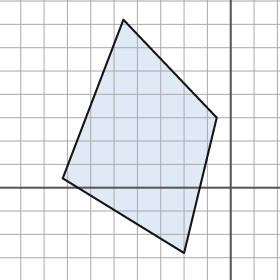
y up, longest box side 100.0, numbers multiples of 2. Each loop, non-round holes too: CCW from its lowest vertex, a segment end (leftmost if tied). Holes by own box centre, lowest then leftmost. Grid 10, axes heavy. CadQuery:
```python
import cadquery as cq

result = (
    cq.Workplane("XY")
    .moveTo(-20.0, -28.0)
    .lineTo(-6.0, 30.0)
    .lineTo(-46.0, 72.0)
    .lineTo(-72.0, 4.0)
    .close()
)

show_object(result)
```